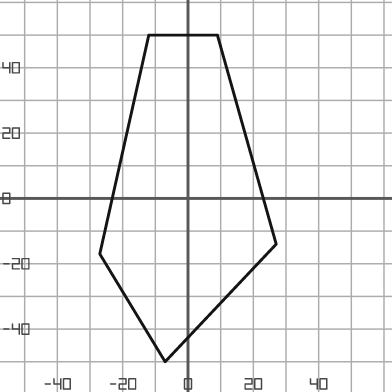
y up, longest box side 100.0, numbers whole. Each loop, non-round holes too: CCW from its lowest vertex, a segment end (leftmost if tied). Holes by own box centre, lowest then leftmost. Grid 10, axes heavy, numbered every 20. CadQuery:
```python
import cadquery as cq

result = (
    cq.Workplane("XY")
    .moveTo(-7.0, -50.0)
    .lineTo(27.0, -14.0)
    .lineTo(9.0, 50.0)
    .lineTo(-12.0, 50.0)
    .lineTo(-27.0, -17.0)
    .close()
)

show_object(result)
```